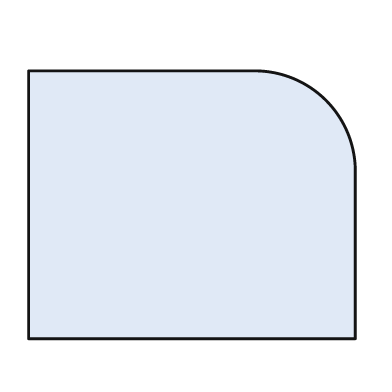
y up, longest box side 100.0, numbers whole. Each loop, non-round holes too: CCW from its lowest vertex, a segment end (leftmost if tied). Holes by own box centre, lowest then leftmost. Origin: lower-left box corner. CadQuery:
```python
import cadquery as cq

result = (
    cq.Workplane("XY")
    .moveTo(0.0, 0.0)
    .lineTo(100.0, 0.0)
    .lineTo(100.0, 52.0)
    .threePointArc((91.0, 73.0), (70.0, 82.0))
    .lineTo(0.0, 82.0)
    .close()
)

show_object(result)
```